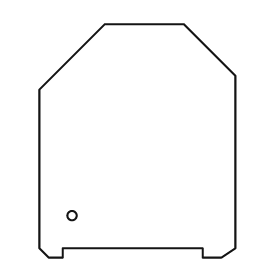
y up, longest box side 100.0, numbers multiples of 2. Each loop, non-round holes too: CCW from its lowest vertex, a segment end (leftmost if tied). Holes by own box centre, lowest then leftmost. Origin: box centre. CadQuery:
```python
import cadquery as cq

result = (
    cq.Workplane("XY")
    .moveTo(-38.0, -50.0)
    .lineTo(-32.0, -50.0)
    .lineTo(-32.0, -46.0)
    .lineTo(28.0, -46.0)
    .lineTo(28.0, -50.0)
    .lineTo(36.0, -50.0)
    .lineTo(42.0, -46.0)
    .lineTo(42.0, 28.0)
    .lineTo(20.0, 50.0)
    .lineTo(-14.0, 50.0)
    .lineTo(-42.0, 22.0)
    .lineTo(-42.0, -46.0)
    .close()
    .moveTo(-28.0, -32.0)
    .circle(2.0)
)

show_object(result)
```